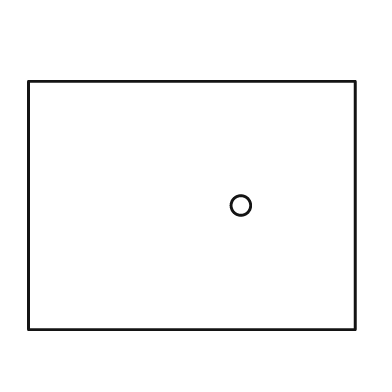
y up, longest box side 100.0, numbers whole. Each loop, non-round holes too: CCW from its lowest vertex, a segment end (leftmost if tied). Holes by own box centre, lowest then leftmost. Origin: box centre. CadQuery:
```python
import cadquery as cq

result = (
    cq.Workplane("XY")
    .moveTo(-50.0, -38.0)
    .lineTo(50.0, -38.0)
    .lineTo(50.0, 38.0)
    .lineTo(-50.0, 38.0)
    .close()
    .moveTo(15.0, 0.0)
    .circle(3.0)
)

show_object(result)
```